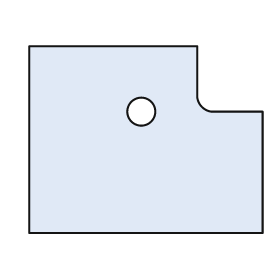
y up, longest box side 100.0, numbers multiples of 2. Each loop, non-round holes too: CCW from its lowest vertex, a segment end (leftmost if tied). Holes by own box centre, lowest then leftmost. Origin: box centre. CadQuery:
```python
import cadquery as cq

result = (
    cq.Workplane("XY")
    .moveTo(-50.0, -40.0)
    .lineTo(50.0, -40.0)
    .lineTo(50.0, 12.0)
    .lineTo(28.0, 12.0)
    .threePointArc((24.0, 14.0), (22.0, 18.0))
    .lineTo(22.0, 40.0)
    .lineTo(-50.0, 40.0)
    .close()
    .moveTo(-2.0, 12.0)
    .circle(6.0)
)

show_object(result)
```